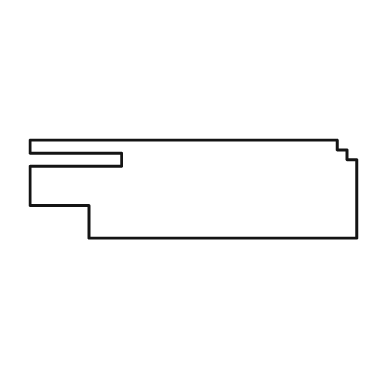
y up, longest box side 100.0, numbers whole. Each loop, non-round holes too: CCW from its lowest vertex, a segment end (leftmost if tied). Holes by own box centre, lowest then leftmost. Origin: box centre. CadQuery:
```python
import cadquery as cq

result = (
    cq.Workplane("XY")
    .moveTo(-32.0, -15.0)
    .lineTo(50.0, -15.0)
    .lineTo(50.0, 9.0)
    .lineTo(47.0, 9.0)
    .lineTo(47.0, 12.0)
    .lineTo(44.0, 12.0)
    .lineTo(44.0, 15.0)
    .lineTo(-50.0, 15.0)
    .lineTo(-50.0, 11.0)
    .lineTo(-22.0, 11.0)
    .lineTo(-22.0, 7.0)
    .lineTo(-50.0, 7.0)
    .lineTo(-50.0, -5.0)
    .lineTo(-32.0, -5.0)
    .close()
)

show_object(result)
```